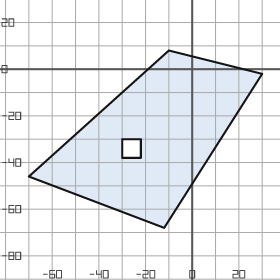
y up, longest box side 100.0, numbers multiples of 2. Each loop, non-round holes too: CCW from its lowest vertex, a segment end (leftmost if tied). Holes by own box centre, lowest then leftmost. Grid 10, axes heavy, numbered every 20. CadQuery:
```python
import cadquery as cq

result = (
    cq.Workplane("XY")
    .moveTo(-12.0, -68.0)
    .lineTo(30.0, -2.0)
    .lineTo(-10.0, 8.0)
    .lineTo(-70.0, -46.0)
    .close()
    .moveTo(-30.0, -38.0)
    .lineTo(-22.0, -38.0)
    .lineTo(-22.0, -30.0)
    .lineTo(-30.0, -30.0)
    .close()
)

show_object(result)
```